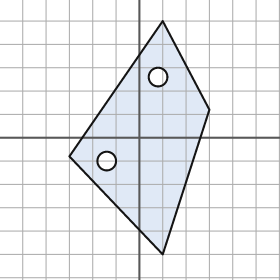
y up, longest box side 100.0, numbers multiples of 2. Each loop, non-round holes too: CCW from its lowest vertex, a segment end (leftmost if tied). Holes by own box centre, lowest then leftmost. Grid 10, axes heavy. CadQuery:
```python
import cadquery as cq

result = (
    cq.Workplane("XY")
    .moveTo(10.0, -50.0)
    .lineTo(30.0, 12.0)
    .lineTo(10.0, 50.0)
    .lineTo(-30.0, -8.0)
    .close()
    .moveTo(-14.0, -10.0)
    .circle(4.0)
    .moveTo(8.0, 26.0)
    .circle(4.0)
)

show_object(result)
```